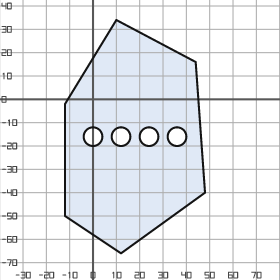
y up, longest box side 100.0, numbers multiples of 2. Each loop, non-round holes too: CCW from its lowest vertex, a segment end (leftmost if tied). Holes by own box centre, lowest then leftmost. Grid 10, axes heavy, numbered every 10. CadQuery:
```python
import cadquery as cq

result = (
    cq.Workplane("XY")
    .moveTo(12.0, -66.0)
    .lineTo(48.0, -40.0)
    .lineTo(44.0, 16.0)
    .lineTo(10.0, 34.0)
    .lineTo(-12.0, -2.0)
    .lineTo(-12.0, -50.0)
    .close()
    .moveTo(0.0, -16.0)
    .circle(4.0)
    .moveTo(12.0, -16.0)
    .circle(4.0)
    .moveTo(24.0, -16.0)
    .circle(4.0)
    .moveTo(36.0, -16.0)
    .circle(4.0)
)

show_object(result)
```